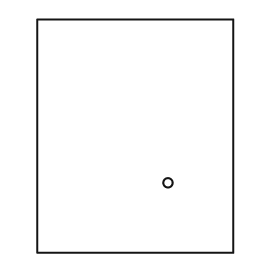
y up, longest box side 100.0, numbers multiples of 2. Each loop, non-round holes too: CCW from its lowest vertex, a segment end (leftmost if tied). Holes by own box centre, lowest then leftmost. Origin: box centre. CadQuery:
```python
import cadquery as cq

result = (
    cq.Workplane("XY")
    .moveTo(-42.0, -50.0)
    .lineTo(42.0, -50.0)
    .lineTo(42.0, 50.0)
    .lineTo(-42.0, 50.0)
    .close()
    .moveTo(14.0, -20.0)
    .circle(2.0)
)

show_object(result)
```